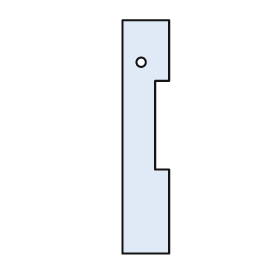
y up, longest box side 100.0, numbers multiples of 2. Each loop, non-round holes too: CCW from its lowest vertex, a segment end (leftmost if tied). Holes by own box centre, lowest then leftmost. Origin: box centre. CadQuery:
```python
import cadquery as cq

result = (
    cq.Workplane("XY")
    .moveTo(-10.0, -50.0)
    .lineTo(10.0, -50.0)
    .lineTo(10.0, -14.0)
    .lineTo(4.0, -14.0)
    .lineTo(4.0, 24.0)
    .lineTo(10.0, 24.0)
    .lineTo(10.0, 50.0)
    .lineTo(-10.0, 50.0)
    .close()
    .moveTo(-2.0, 32.0)
    .circle(2.0)
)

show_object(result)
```